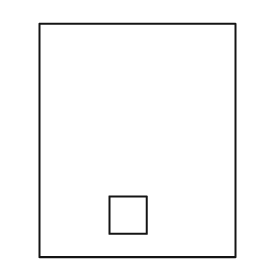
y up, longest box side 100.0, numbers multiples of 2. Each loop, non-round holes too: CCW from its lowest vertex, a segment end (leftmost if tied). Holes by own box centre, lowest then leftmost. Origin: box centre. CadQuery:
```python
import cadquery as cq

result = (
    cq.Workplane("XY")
    .moveTo(-42.0, -50.0)
    .lineTo(42.0, -50.0)
    .lineTo(42.0, 50.0)
    .lineTo(-42.0, 50.0)
    .close()
    .moveTo(-12.0, -40.0)
    .lineTo(4.0, -40.0)
    .lineTo(4.0, -24.0)
    .lineTo(-12.0, -24.0)
    .close()
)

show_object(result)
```